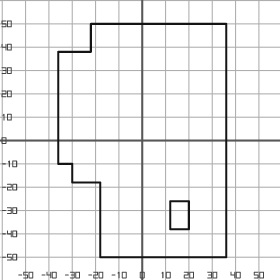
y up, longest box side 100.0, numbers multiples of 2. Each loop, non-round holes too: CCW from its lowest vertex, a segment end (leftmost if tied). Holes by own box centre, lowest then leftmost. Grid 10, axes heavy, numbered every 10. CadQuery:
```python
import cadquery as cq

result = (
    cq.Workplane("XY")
    .moveTo(-18.0, -50.0)
    .lineTo(36.0, -50.0)
    .lineTo(36.0, 50.0)
    .lineTo(-22.0, 50.0)
    .lineTo(-22.0, 38.0)
    .lineTo(-36.0, 38.0)
    .lineTo(-36.0, -10.0)
    .lineTo(-30.0, -10.0)
    .lineTo(-30.0, -18.0)
    .lineTo(-18.0, -18.0)
    .close()
    .moveTo(12.0, -38.0)
    .lineTo(20.0, -38.0)
    .lineTo(20.0, -26.0)
    .lineTo(12.0, -26.0)
    .close()
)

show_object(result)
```